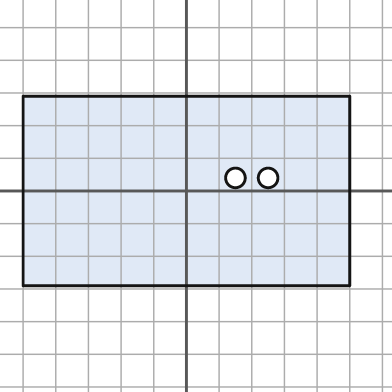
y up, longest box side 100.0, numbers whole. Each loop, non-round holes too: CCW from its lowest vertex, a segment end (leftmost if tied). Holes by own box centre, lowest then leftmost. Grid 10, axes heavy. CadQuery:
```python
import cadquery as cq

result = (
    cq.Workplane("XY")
    .moveTo(-50.0, -29.0)
    .lineTo(50.0, -29.0)
    .lineTo(50.0, 29.0)
    .lineTo(-50.0, 29.0)
    .close()
    .moveTo(15.0, 4.0)
    .circle(3.0)
    .moveTo(25.0, 4.0)
    .circle(3.0)
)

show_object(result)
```